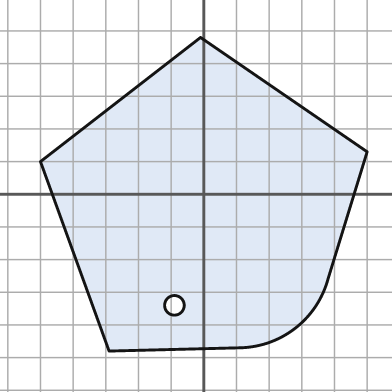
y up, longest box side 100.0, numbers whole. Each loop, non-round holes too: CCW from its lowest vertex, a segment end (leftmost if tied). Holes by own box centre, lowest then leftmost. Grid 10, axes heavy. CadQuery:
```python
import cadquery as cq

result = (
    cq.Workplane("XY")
    .moveTo(-29.0, -48.0)
    .lineTo(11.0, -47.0)
    .threePointArc((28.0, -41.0), (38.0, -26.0))
    .lineTo(50.0, 13.0)
    .lineTo(-1.0, 48.0)
    .lineTo(-50.0, 10.0)
    .close()
    .moveTo(-9.0, -34.0)
    .circle(3.0)
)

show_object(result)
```